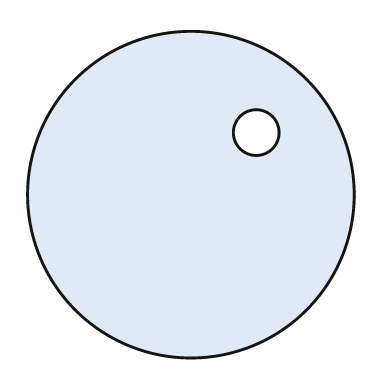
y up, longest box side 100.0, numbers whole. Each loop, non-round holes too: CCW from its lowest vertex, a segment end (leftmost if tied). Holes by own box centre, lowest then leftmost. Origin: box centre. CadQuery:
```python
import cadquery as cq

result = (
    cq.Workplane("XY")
    .moveTo(0.0, 0.0)
    .circle(50.0)
    .moveTo(20.0, 19.0)
    .circle(7.0)
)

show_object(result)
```